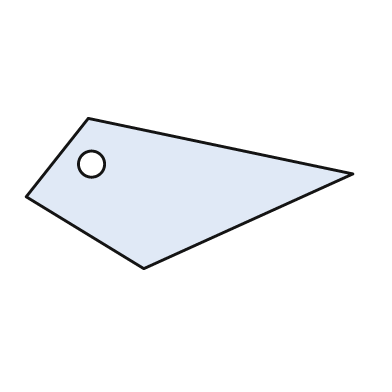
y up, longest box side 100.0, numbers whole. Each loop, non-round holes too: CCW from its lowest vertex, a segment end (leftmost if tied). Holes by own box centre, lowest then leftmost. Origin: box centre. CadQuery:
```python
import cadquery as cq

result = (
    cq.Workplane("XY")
    .moveTo(-14.0, -23.0)
    .lineTo(50.0, 6.0)
    .lineTo(-31.0, 23.0)
    .lineTo(-50.0, -1.0)
    .close()
    .moveTo(-30.0, 9.0)
    .circle(4.0)
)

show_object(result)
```